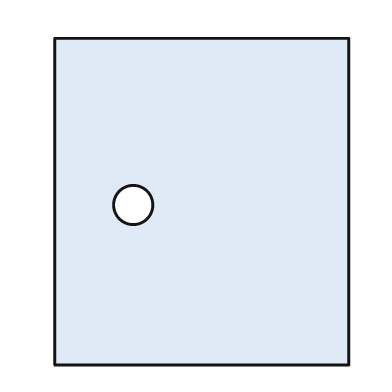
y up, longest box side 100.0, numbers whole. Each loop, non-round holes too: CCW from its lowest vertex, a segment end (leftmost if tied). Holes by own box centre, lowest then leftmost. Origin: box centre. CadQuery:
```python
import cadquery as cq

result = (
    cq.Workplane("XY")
    .moveTo(-45.0, -50.0)
    .lineTo(45.0, -50.0)
    .lineTo(45.0, 50.0)
    .lineTo(-45.0, 50.0)
    .close()
    .moveTo(-21.0, -1.0)
    .circle(6.0)
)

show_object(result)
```